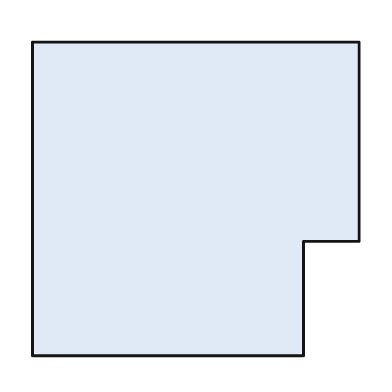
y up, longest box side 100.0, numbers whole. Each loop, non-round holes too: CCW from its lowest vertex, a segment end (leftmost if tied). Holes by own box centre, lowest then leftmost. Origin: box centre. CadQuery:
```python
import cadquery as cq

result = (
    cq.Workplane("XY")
    .moveTo(-50.0, -48.0)
    .lineTo(33.0, -48.0)
    .lineTo(33.0, -13.0)
    .lineTo(50.0, -13.0)
    .lineTo(50.0, 48.0)
    .lineTo(-50.0, 48.0)
    .close()
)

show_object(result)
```